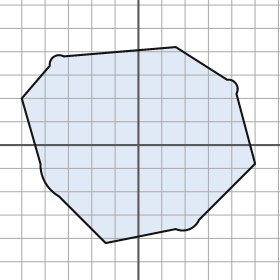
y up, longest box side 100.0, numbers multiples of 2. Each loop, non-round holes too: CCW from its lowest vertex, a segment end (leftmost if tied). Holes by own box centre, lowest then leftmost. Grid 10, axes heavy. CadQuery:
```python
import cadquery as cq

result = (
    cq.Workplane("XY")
    .moveTo(-14.0, -42.0)
    .lineTo(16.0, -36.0)
    .threePointArc((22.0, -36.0), (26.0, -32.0))
    .lineTo(50.0, -8.0)
    .lineTo(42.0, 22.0)
    .threePointArc((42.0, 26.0), (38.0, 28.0))
    .lineTo(16.0, 42.0)
    .lineTo(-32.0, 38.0)
    .threePointArc((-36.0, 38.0), (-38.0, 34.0))
    .lineTo(-50.0, 20.0)
    .lineTo(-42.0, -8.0)
    .threePointArc((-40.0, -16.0), (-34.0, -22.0))
    .close()
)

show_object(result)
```